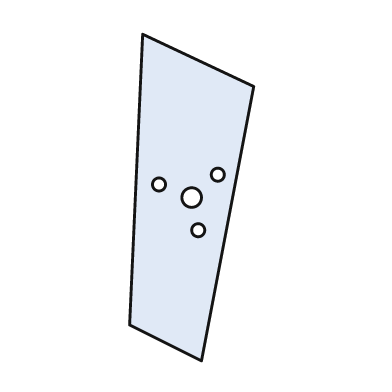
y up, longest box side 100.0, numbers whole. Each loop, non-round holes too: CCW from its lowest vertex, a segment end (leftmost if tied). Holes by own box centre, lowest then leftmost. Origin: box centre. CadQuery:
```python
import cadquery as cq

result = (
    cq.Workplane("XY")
    .moveTo(3.0, -50.0)
    .lineTo(19.0, 34.0)
    .lineTo(-15.0, 50.0)
    .lineTo(-19.0, -39.0)
    .close()
    .moveTo(2.0, -10.0)
    .circle(2.0)
    .moveTo(0.0, 0.0)
    .circle(3.0)
    .moveTo(-10.0, 4.0)
    .circle(2.0)
    .moveTo(8.0, 7.0)
    .circle(2.0)
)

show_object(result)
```